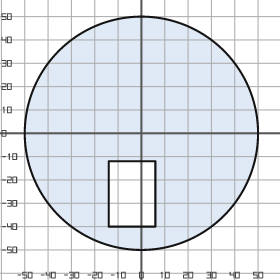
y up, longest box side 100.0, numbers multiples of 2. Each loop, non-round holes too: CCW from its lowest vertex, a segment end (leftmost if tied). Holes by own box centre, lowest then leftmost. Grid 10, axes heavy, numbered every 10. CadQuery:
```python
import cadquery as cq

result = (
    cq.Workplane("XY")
    .moveTo(0.0, 0.0)
    .circle(50.0)
    .moveTo(-14.0, -40.0)
    .lineTo(6.0, -40.0)
    .lineTo(6.0, -12.0)
    .lineTo(-14.0, -12.0)
    .close()
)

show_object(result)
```